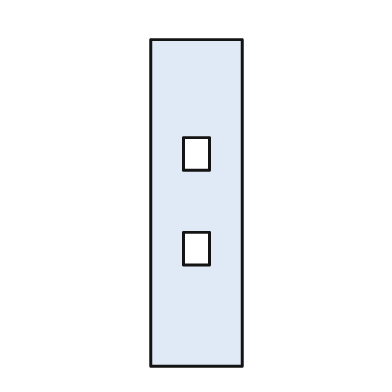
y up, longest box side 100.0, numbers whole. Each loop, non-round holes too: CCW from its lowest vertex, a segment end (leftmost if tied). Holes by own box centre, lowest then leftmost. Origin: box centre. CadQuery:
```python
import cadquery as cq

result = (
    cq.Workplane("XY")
    .moveTo(-14.0, -50.0)
    .lineTo(14.0, -50.0)
    .lineTo(14.0, 50.0)
    .lineTo(-14.0, 50.0)
    .close()
    .moveTo(-4.0, -19.0)
    .lineTo(4.0, -19.0)
    .lineTo(4.0, -9.0)
    .lineTo(-4.0, -9.0)
    .close()
    .moveTo(-4.0, 10.0)
    .lineTo(4.0, 10.0)
    .lineTo(4.0, 20.0)
    .lineTo(-4.0, 20.0)
    .close()
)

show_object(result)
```